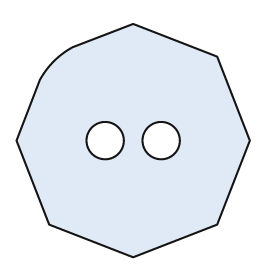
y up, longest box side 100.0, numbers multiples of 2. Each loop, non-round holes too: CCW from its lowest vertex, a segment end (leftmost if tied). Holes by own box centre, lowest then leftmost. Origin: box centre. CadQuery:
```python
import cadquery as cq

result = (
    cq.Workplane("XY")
    .moveTo(0.0, -50.0)
    .lineTo(36.0, -36.0)
    .lineTo(50.0, 0.0)
    .lineTo(36.0, 36.0)
    .lineTo(0.0, 50.0)
    .lineTo(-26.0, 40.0)
    .threePointArc((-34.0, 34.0), (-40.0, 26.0))
    .lineTo(-50.0, 0.0)
    .lineTo(-36.0, -36.0)
    .close()
    .moveTo(-12.0, 0.0)
    .circle(8.0)
    .moveTo(12.0, 0.0)
    .circle(8.0)
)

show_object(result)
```